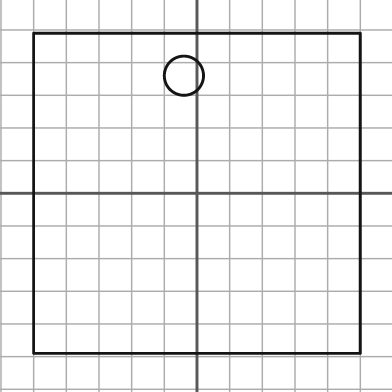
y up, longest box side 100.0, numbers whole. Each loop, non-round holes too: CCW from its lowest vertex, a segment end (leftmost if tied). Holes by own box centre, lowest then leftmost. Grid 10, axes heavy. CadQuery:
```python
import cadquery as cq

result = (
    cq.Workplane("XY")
    .moveTo(-50.0, -49.0)
    .lineTo(50.0, -49.0)
    .lineTo(50.0, 49.0)
    .lineTo(-50.0, 49.0)
    .close()
    .moveTo(-4.0, 36.0)
    .circle(6.0)
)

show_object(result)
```